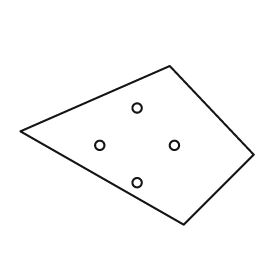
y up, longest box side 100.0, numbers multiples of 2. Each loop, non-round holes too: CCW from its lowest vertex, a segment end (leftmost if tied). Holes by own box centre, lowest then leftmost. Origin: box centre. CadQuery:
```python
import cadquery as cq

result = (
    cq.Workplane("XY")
    .moveTo(20.0, -34.0)
    .lineTo(50.0, -4.0)
    .lineTo(14.0, 34.0)
    .lineTo(-50.0, 6.0)
    .close()
    .moveTo(0.0, -16.0)
    .circle(2.0)
    .moveTo(-16.0, 0.0)
    .circle(2.0)
    .moveTo(16.0, 0.0)
    .circle(2.0)
    .moveTo(0.0, 16.0)
    .circle(2.0)
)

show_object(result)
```